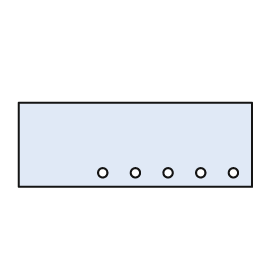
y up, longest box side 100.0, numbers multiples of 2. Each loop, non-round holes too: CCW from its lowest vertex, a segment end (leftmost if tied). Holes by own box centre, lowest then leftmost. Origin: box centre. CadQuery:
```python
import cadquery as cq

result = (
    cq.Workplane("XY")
    .moveTo(-50.0, -18.0)
    .lineTo(50.0, -18.0)
    .lineTo(50.0, 18.0)
    .lineTo(-50.0, 18.0)
    .close()
    .moveTo(-14.0, -12.0)
    .circle(2.0)
    .moveTo(0.0, -12.0)
    .circle(2.0)
    .moveTo(14.0, -12.0)
    .circle(2.0)
    .moveTo(28.0, -12.0)
    .circle(2.0)
    .moveTo(42.0, -12.0)
    .circle(2.0)
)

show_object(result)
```